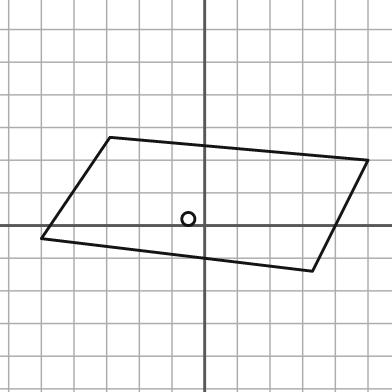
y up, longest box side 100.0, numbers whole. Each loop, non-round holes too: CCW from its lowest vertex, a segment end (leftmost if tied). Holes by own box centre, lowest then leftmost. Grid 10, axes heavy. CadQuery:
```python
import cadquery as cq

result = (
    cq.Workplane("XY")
    .moveTo(33.0, -14.0)
    .lineTo(50.0, 20.0)
    .lineTo(-29.0, 27.0)
    .lineTo(-50.0, -4.0)
    .close()
    .moveTo(-5.0, 2.0)
    .circle(2.0)
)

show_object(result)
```